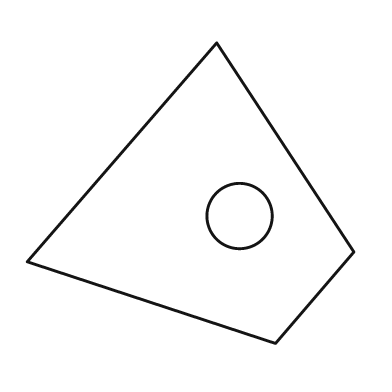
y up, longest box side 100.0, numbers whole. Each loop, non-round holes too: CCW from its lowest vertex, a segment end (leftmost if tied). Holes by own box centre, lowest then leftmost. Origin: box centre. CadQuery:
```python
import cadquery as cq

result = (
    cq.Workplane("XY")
    .moveTo(26.0, -46.0)
    .lineTo(50.0, -18.0)
    .lineTo(8.0, 46.0)
    .lineTo(-50.0, -21.0)
    .close()
    .moveTo(15.0, -7.0)
    .circle(10.0)
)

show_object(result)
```